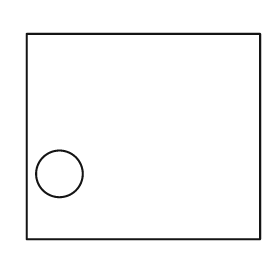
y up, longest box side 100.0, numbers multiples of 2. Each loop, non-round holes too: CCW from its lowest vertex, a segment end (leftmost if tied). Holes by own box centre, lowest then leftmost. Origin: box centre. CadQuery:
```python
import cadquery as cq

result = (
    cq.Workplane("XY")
    .moveTo(-50.0, -44.0)
    .lineTo(50.0, -44.0)
    .lineTo(50.0, 44.0)
    .lineTo(-50.0, 44.0)
    .close()
    .moveTo(-36.0, -16.0)
    .circle(10.0)
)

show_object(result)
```